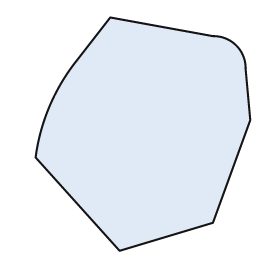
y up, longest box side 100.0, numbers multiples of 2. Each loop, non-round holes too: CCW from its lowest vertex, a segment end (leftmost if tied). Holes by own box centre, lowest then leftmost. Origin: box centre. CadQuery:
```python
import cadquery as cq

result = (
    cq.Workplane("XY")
    .moveTo(-10.0, -50.0)
    .lineTo(30.0, -38.0)
    .lineTo(46.0, 6.0)
    .lineTo(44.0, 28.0)
    .threePointArc((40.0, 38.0), (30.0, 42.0))
    .lineTo(-14.0, 50.0)
    .lineTo(-28.0, 32.0)
    .threePointArc((-40.0, 12.0), (-46.0, -10.0))
    .close()
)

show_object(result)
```